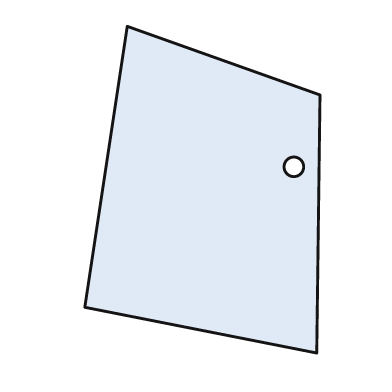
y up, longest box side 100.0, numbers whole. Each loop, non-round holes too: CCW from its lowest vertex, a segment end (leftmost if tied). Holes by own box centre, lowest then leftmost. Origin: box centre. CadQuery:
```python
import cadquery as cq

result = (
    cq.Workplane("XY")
    .moveTo(35.0, -50.0)
    .lineTo(36.0, 29.0)
    .lineTo(-23.0, 50.0)
    .lineTo(-36.0, -36.0)
    .close()
    .moveTo(28.0, 7.0)
    .circle(3.0)
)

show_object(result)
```